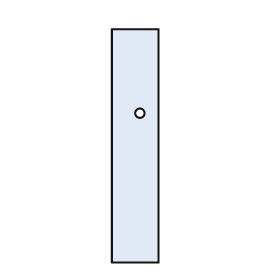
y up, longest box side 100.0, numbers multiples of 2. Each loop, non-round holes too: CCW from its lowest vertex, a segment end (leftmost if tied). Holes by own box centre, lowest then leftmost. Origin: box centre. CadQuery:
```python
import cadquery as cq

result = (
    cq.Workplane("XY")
    .moveTo(-10.0, -50.0)
    .lineTo(10.0, -50.0)
    .lineTo(10.0, 50.0)
    .lineTo(-10.0, 50.0)
    .close()
    .moveTo(2.0, 14.0)
    .circle(2.0)
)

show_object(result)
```